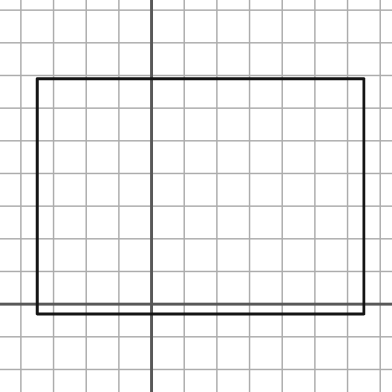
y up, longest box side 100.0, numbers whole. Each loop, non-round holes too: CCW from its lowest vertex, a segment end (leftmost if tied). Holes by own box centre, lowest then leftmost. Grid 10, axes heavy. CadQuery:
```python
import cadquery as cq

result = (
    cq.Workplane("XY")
    .moveTo(-35.0, -3.0)
    .lineTo(65.0, -3.0)
    .lineTo(65.0, 69.0)
    .lineTo(-35.0, 69.0)
    .close()
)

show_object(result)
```